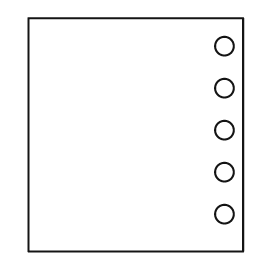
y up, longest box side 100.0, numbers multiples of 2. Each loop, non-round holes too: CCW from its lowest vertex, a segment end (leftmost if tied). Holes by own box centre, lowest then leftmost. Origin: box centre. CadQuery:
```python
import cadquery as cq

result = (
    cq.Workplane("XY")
    .moveTo(-46.0, -50.0)
    .lineTo(46.0, -50.0)
    .lineTo(46.0, 50.0)
    .lineTo(-46.0, 50.0)
    .close()
    .moveTo(38.0, -34.0)
    .circle(4.0)
    .moveTo(38.0, -16.0)
    .circle(4.0)
    .moveTo(38.0, 2.0)
    .circle(4.0)
    .moveTo(38.0, 20.0)
    .circle(4.0)
    .moveTo(38.0, 38.0)
    .circle(4.0)
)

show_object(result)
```